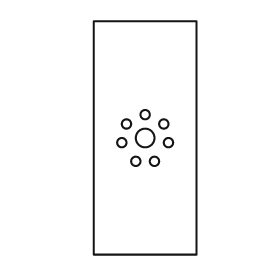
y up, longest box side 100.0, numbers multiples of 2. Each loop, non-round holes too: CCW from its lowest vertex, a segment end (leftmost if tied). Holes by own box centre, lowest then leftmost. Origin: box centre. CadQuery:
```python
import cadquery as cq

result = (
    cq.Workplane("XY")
    .moveTo(-22.0, -50.0)
    .lineTo(22.0, -50.0)
    .lineTo(22.0, 50.0)
    .lineTo(-22.0, 50.0)
    .close()
    .moveTo(-4.0, -10.0)
    .circle(2.0)
    .moveTo(4.0, -10.0)
    .circle(2.0)
    .moveTo(-10.0, -2.0)
    .circle(2.0)
    .moveTo(10.0, -2.0)
    .circle(2.0)
    .moveTo(0.0, 0.0)
    .circle(4.0)
    .moveTo(-8.0, 6.0)
    .circle(2.0)
    .moveTo(8.0, 6.0)
    .circle(2.0)
    .moveTo(0.0, 10.0)
    .circle(2.0)
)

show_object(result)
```